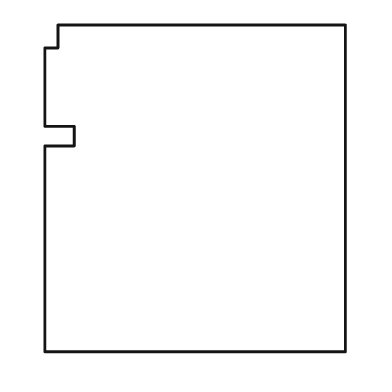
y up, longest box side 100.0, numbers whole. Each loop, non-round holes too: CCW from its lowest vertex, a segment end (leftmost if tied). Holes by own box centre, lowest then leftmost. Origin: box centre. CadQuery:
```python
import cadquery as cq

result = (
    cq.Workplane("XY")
    .moveTo(-46.0, -50.0)
    .lineTo(46.0, -50.0)
    .lineTo(46.0, 50.0)
    .lineTo(-42.0, 50.0)
    .lineTo(-42.0, 43.0)
    .lineTo(-46.0, 43.0)
    .lineTo(-46.0, 19.0)
    .lineTo(-37.0, 19.0)
    .lineTo(-37.0, 13.0)
    .lineTo(-46.0, 13.0)
    .close()
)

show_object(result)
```